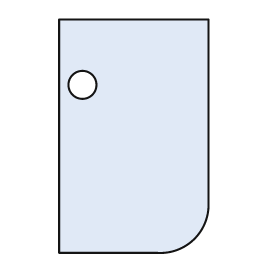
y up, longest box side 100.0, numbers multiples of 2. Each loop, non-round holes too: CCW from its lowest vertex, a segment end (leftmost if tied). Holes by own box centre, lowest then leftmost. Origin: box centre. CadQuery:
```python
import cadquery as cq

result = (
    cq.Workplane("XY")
    .moveTo(-32.0, -50.0)
    .lineTo(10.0, -50.0)
    .threePointArc((26.0, -44.0), (32.0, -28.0))
    .lineTo(32.0, 50.0)
    .lineTo(-32.0, 50.0)
    .close()
    .moveTo(-22.0, 22.0)
    .circle(6.0)
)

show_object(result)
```